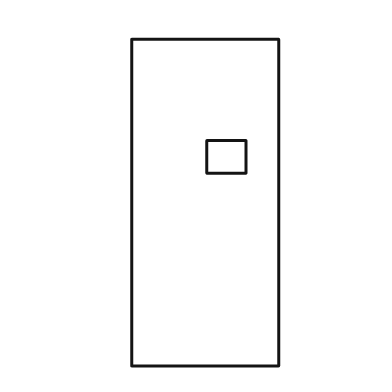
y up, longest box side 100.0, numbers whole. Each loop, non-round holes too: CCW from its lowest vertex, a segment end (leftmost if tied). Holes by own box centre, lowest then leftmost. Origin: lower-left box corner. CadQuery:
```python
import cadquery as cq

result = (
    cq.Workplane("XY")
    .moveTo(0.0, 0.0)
    .lineTo(45.0, 0.0)
    .lineTo(45.0, 100.0)
    .lineTo(0.0, 100.0)
    .close()
    .moveTo(23.0, 59.0)
    .lineTo(35.0, 59.0)
    .lineTo(35.0, 69.0)
    .lineTo(23.0, 69.0)
    .close()
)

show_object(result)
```